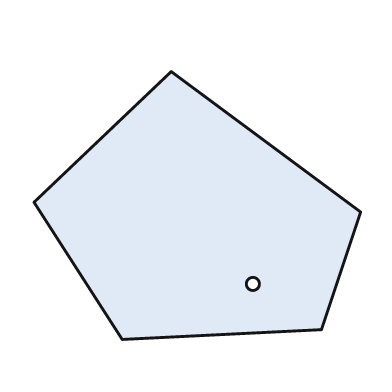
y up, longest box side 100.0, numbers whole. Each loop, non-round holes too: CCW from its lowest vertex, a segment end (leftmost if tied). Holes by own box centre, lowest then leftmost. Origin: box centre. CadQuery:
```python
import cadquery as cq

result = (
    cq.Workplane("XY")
    .moveTo(-23.0, -41.0)
    .lineTo(38.0, -38.0)
    .lineTo(50.0, -2.0)
    .lineTo(-8.0, 41.0)
    .lineTo(-50.0, 1.0)
    .close()
    .moveTo(17.0, -24.0)
    .circle(2.0)
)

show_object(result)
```